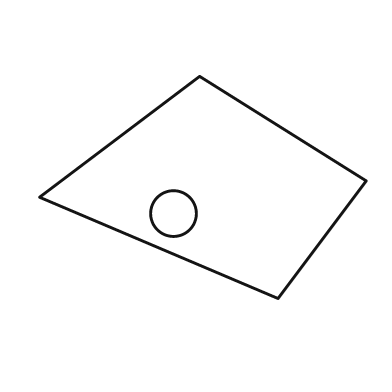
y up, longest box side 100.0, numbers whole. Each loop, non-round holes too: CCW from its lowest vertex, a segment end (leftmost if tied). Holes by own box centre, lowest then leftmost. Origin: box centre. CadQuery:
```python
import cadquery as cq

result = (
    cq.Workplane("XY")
    .moveTo(23.0, -34.0)
    .lineTo(50.0, 2.0)
    .lineTo(-1.0, 34.0)
    .lineTo(-50.0, -3.0)
    .close()
    .moveTo(-9.0, -8.0)
    .circle(7.0)
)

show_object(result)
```